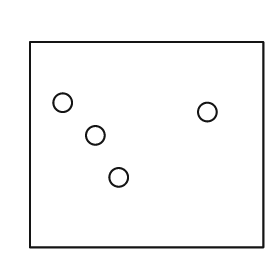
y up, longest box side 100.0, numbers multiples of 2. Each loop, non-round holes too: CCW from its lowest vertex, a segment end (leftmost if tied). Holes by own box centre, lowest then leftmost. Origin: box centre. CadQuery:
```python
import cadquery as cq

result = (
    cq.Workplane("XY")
    .moveTo(-50.0, -44.0)
    .lineTo(50.0, -44.0)
    .lineTo(50.0, 44.0)
    .lineTo(-50.0, 44.0)
    .close()
    .moveTo(-12.0, -14.0)
    .circle(4.0)
    .moveTo(-22.0, 4.0)
    .circle(4.0)
    .moveTo(26.0, 14.0)
    .circle(4.0)
    .moveTo(-36.0, 18.0)
    .circle(4.0)
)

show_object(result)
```